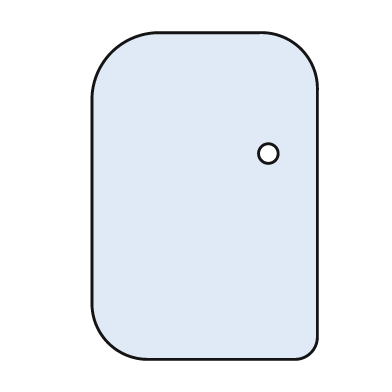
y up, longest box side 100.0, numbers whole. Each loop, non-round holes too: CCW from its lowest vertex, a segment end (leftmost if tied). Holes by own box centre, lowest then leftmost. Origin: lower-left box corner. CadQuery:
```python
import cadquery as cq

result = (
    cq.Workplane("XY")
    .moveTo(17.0, 0.0)
    .lineTo(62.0, 0.0)
    .threePointArc((67.0, 2.0), (69.0, 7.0))
    .lineTo(69.0, 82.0)
    .threePointArc((64.0, 95.0), (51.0, 100.0))
    .lineTo(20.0, 100.0)
    .threePointArc((6.0, 94.0), (0.0, 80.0))
    .lineTo(0.0, 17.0)
    .threePointArc((5.0, 5.0), (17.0, 0.0))
    .close()
    .moveTo(54.0, 63.0)
    .circle(3.0)
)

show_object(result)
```